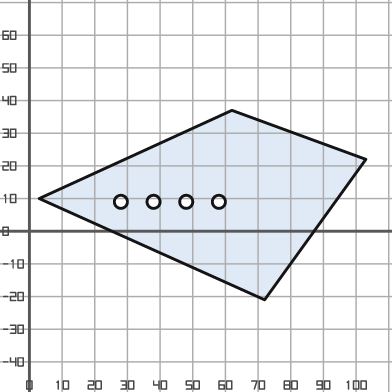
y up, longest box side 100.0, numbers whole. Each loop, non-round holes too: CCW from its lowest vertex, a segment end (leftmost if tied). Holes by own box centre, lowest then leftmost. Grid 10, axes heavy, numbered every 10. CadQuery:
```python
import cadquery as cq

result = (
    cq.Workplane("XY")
    .moveTo(72.0, -21.0)
    .lineTo(103.0, 22.0)
    .lineTo(62.0, 37.0)
    .lineTo(3.0, 10.0)
    .close()
    .moveTo(28.0, 9.0)
    .circle(2.0)
    .moveTo(38.0, 9.0)
    .circle(2.0)
    .moveTo(48.0, 9.0)
    .circle(2.0)
    .moveTo(58.0, 9.0)
    .circle(2.0)
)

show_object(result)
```